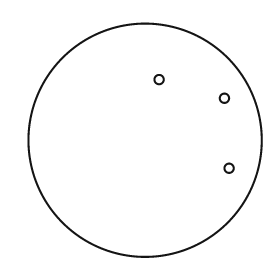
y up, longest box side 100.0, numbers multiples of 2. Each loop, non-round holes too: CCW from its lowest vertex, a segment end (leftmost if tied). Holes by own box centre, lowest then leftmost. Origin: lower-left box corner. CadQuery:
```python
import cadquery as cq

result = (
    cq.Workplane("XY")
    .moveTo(50.0, 50.0)
    .circle(50.0)
    .moveTo(86.0, 38.0)
    .circle(2.0)
    .moveTo(84.0, 68.0)
    .circle(2.0)
    .moveTo(56.0, 76.0)
    .circle(2.0)
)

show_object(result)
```